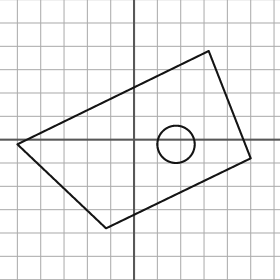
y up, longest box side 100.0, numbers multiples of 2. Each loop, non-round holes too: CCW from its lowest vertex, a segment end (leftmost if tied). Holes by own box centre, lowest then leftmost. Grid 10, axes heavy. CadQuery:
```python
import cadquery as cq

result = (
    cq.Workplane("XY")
    .moveTo(-12.0, -38.0)
    .lineTo(50.0, -8.0)
    .lineTo(32.0, 38.0)
    .lineTo(-50.0, -2.0)
    .close()
    .moveTo(18.0, -2.0)
    .circle(8.0)
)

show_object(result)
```